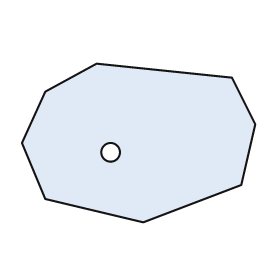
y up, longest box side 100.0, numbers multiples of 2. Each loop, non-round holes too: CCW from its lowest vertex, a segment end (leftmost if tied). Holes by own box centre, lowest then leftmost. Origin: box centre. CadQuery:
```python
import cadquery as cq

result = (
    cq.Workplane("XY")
    .moveTo(2.0, -34.0)
    .lineTo(44.0, -18.0)
    .lineTo(50.0, 8.0)
    .lineTo(40.0, 28.0)
    .lineTo(-18.0, 34.0)
    .lineTo(-40.0, 22.0)
    .lineTo(-50.0, 0.0)
    .lineTo(-40.0, -24.0)
    .close()
    .moveTo(-12.0, -4.0)
    .circle(4.0)
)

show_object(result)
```